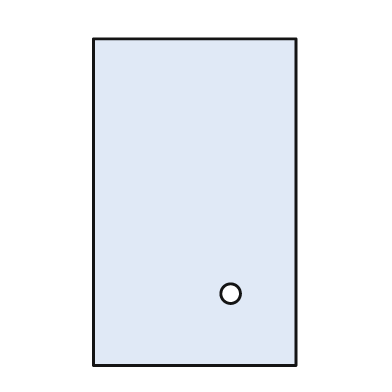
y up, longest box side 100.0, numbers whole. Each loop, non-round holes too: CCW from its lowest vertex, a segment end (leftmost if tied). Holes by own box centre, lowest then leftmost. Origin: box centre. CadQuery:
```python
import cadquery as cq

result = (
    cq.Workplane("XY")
    .moveTo(-31.0, -50.0)
    .lineTo(31.0, -50.0)
    .lineTo(31.0, 50.0)
    .lineTo(-31.0, 50.0)
    .close()
    .moveTo(11.0, -28.0)
    .circle(3.0)
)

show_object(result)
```